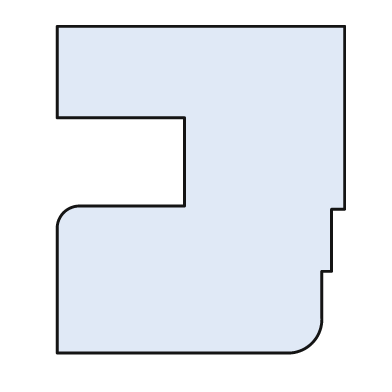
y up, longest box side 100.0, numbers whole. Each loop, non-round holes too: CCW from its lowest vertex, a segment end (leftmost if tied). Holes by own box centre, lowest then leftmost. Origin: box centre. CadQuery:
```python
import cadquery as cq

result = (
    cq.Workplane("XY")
    .moveTo(-44.0, -50.0)
    .lineTo(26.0, -50.0)
    .threePointArc((34.0, -47.0), (37.0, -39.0))
    .lineTo(37.0, -25.0)
    .lineTo(40.0, -25.0)
    .lineTo(40.0, -6.0)
    .lineTo(44.0, -6.0)
    .lineTo(44.0, 50.0)
    .lineTo(-44.0, 50.0)
    .lineTo(-44.0, 22.0)
    .lineTo(-5.0, 22.0)
    .lineTo(-5.0, -5.0)
    .lineTo(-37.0, -5.0)
    .threePointArc((-42.0, -7.0), (-44.0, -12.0))
    .close()
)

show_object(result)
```